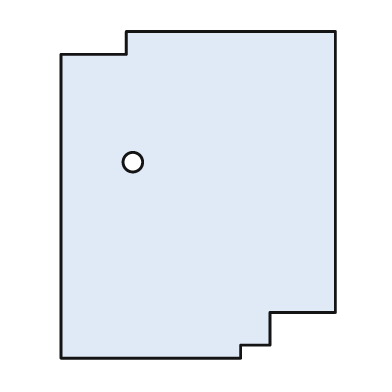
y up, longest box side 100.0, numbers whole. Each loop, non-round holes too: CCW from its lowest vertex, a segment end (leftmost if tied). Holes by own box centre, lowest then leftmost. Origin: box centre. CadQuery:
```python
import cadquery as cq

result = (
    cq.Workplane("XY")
    .moveTo(-42.0, -50.0)
    .lineTo(13.0, -50.0)
    .lineTo(13.0, -46.0)
    .lineTo(22.0, -46.0)
    .lineTo(22.0, -36.0)
    .lineTo(42.0, -36.0)
    .lineTo(42.0, 50.0)
    .lineTo(-22.0, 50.0)
    .lineTo(-22.0, 43.0)
    .lineTo(-42.0, 43.0)
    .close()
    .moveTo(-20.0, 10.0)
    .circle(3.0)
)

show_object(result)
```